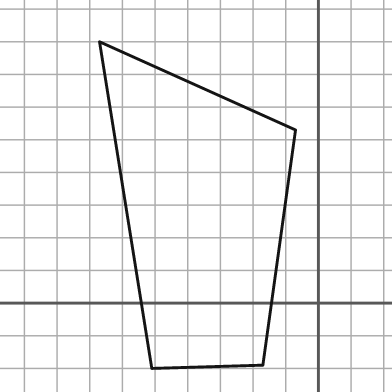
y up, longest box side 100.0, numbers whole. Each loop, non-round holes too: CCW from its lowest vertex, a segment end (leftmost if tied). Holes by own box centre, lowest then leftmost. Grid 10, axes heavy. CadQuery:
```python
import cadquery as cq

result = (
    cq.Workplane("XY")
    .moveTo(-51.0, -20.0)
    .lineTo(-17.0, -19.0)
    .lineTo(-7.0, 53.0)
    .lineTo(-67.0, 80.0)
    .close()
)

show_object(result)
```